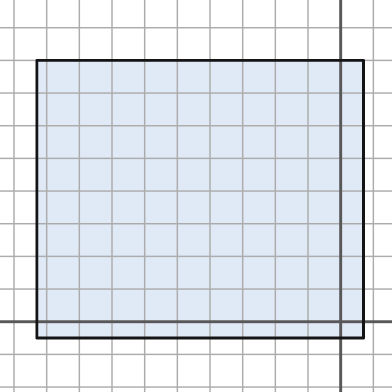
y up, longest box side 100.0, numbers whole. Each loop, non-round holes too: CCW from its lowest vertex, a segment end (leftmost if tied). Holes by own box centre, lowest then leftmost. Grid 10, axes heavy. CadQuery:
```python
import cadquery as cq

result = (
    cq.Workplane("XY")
    .moveTo(-93.0, -5.0)
    .lineTo(7.0, -5.0)
    .lineTo(7.0, 80.0)
    .lineTo(-93.0, 80.0)
    .close()
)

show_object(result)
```